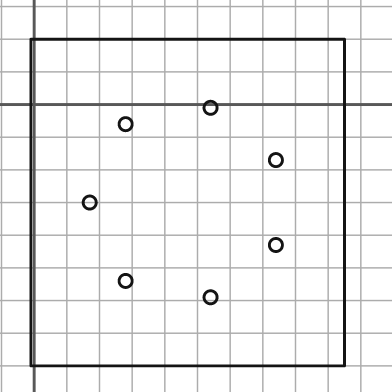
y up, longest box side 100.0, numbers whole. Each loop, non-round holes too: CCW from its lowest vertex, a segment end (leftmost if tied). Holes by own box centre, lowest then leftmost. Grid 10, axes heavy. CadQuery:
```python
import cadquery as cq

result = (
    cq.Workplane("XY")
    .moveTo(-1.0, -80.0)
    .lineTo(95.0, -80.0)
    .lineTo(95.0, 20.0)
    .lineTo(-1.0, 20.0)
    .close()
    .moveTo(54.0, -59.0)
    .circle(2.0)
    .moveTo(28.0, -54.0)
    .circle(2.0)
    .moveTo(74.0, -43.0)
    .circle(2.0)
    .moveTo(17.0, -30.0)
    .circle(2.0)
    .moveTo(74.0, -17.0)
    .circle(2.0)
    .moveTo(28.0, -6.0)
    .circle(2.0)
    .moveTo(54.0, -1.0)
    .circle(2.0)
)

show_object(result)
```